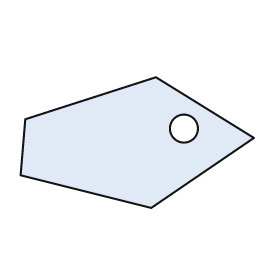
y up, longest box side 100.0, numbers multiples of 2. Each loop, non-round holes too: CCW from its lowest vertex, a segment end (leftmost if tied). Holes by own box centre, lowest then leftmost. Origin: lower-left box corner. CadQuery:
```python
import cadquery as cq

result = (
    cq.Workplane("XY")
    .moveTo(56.0, 0.0)
    .lineTo(100.0, 30.0)
    .lineTo(58.0, 56.0)
    .lineTo(2.0, 38.0)
    .lineTo(0.0, 14.0)
    .close()
    .moveTo(70.0, 34.0)
    .circle(6.0)
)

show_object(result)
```